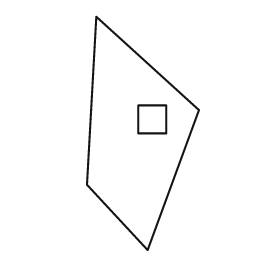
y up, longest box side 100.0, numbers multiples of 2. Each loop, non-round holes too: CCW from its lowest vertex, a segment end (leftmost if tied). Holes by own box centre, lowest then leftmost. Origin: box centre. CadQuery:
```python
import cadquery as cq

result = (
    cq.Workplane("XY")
    .moveTo(2.0, -50.0)
    .lineTo(24.0, 10.0)
    .lineTo(-20.0, 50.0)
    .lineTo(-24.0, -22.0)
    .close()
    .moveTo(-2.0, 0.0)
    .lineTo(10.0, 0.0)
    .lineTo(10.0, 12.0)
    .lineTo(-2.0, 12.0)
    .close()
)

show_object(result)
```